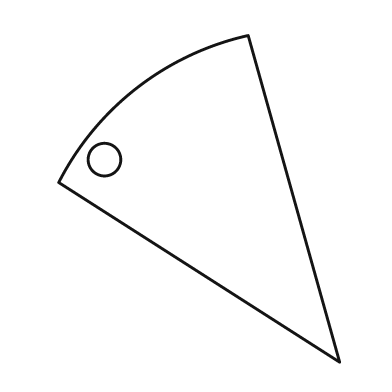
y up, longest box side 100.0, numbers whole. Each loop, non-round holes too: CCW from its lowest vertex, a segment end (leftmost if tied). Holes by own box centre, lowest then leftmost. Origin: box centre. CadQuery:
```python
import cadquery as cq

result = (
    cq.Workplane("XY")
    .moveTo(43.0, -50.0)
    .lineTo(15.0, 50.0)
    .threePointArc((-19.0, 34.0), (-43.0, 5.0))
    .close()
    .moveTo(-29.0, 12.0)
    .circle(5.0)
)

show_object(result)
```